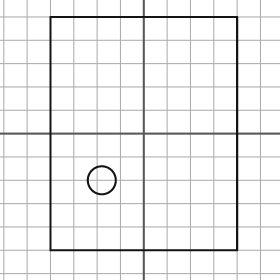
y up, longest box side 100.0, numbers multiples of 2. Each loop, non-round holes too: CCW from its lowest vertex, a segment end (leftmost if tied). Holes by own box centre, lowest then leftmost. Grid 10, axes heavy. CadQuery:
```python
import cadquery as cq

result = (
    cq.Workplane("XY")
    .moveTo(-40.0, -50.0)
    .lineTo(40.0, -50.0)
    .lineTo(40.0, 50.0)
    .lineTo(-40.0, 50.0)
    .close()
    .moveTo(-18.0, -20.0)
    .circle(6.0)
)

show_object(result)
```